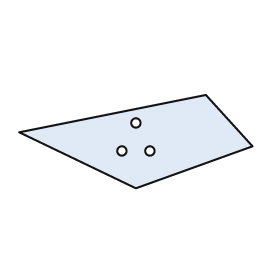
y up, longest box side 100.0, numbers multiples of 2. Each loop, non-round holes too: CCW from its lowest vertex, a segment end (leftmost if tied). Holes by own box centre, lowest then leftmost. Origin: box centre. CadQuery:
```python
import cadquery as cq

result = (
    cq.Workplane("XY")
    .moveTo(0.0, -20.0)
    .lineTo(50.0, -2.0)
    .lineTo(30.0, 20.0)
    .lineTo(-50.0, 4.0)
    .close()
    .moveTo(-6.0, -4.0)
    .circle(2.0)
    .moveTo(6.0, -4.0)
    .circle(2.0)
    .moveTo(0.0, 8.0)
    .circle(2.0)
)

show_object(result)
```